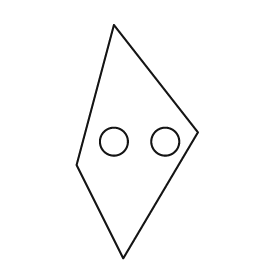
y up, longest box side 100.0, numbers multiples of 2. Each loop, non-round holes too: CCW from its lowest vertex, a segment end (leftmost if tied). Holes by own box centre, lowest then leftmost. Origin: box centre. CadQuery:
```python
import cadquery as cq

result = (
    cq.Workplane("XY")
    .moveTo(-6.0, -50.0)
    .lineTo(26.0, 4.0)
    .lineTo(-10.0, 50.0)
    .lineTo(-26.0, -10.0)
    .close()
    .moveTo(-10.0, 0.0)
    .circle(6.0)
    .moveTo(12.0, 0.0)
    .circle(6.0)
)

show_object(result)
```